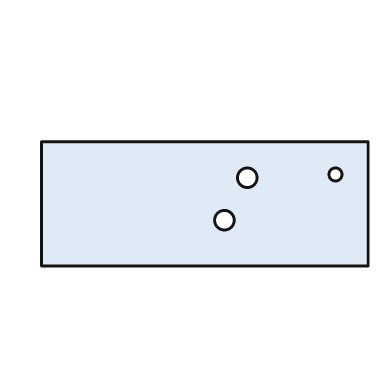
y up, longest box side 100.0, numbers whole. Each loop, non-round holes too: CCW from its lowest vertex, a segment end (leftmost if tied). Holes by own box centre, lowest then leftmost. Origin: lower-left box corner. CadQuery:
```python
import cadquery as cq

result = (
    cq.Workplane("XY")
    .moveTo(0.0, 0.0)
    .lineTo(100.0, 0.0)
    .lineTo(100.0, 38.0)
    .lineTo(0.0, 38.0)
    .close()
    .moveTo(56.0, 14.0)
    .circle(3.0)
    .moveTo(63.0, 27.0)
    .circle(3.0)
    .moveTo(90.0, 28.0)
    .circle(2.0)
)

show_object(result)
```